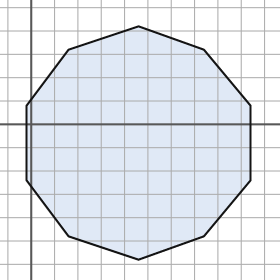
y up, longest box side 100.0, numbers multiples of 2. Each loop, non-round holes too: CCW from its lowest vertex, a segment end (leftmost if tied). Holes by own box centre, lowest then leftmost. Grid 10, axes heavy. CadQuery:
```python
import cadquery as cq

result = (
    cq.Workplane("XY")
    .moveTo(46.0, -58.0)
    .lineTo(74.0, -48.0)
    .lineTo(94.0, -24.0)
    .lineTo(94.0, 8.0)
    .lineTo(74.0, 32.0)
    .lineTo(46.0, 42.0)
    .lineTo(16.0, 32.0)
    .lineTo(-2.0, 8.0)
    .lineTo(-2.0, -24.0)
    .lineTo(16.0, -48.0)
    .close()
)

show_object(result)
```